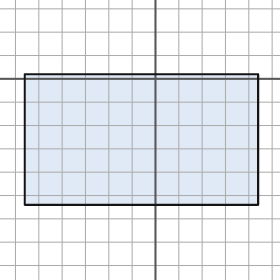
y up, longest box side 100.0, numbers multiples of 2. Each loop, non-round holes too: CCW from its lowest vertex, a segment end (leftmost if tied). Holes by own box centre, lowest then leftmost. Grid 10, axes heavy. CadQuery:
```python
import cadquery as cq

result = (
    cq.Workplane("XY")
    .moveTo(-56.0, -54.0)
    .lineTo(44.0, -54.0)
    .lineTo(44.0, 2.0)
    .lineTo(-56.0, 2.0)
    .close()
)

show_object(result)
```